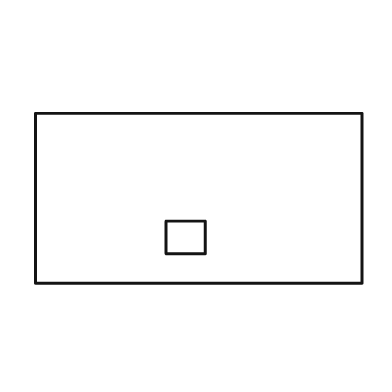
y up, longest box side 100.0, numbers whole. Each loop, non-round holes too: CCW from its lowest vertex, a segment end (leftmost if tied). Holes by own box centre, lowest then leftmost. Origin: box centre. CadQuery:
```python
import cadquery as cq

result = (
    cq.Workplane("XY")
    .moveTo(-50.0, -26.0)
    .lineTo(50.0, -26.0)
    .lineTo(50.0, 26.0)
    .lineTo(-50.0, 26.0)
    .close()
    .moveTo(-10.0, -17.0)
    .lineTo(2.0, -17.0)
    .lineTo(2.0, -7.0)
    .lineTo(-10.0, -7.0)
    .close()
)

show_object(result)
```